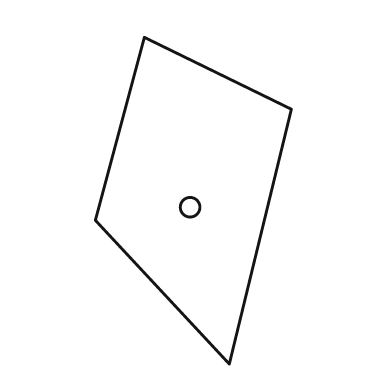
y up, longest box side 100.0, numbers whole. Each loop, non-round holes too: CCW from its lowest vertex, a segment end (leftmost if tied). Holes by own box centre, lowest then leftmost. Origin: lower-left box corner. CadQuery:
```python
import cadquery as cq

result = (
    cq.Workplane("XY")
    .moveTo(41.0, 0.0)
    .lineTo(60.0, 78.0)
    .lineTo(15.0, 100.0)
    .lineTo(0.0, 44.0)
    .close()
    .moveTo(29.0, 48.0)
    .circle(3.0)
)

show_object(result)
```